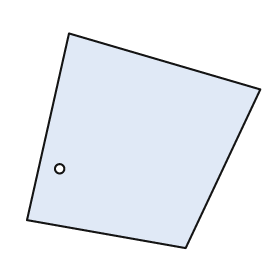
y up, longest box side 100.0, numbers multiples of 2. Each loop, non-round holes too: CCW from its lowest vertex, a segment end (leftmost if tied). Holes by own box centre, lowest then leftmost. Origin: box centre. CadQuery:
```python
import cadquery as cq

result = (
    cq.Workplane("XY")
    .moveTo(18.0, -46.0)
    .lineTo(50.0, 22.0)
    .lineTo(-32.0, 46.0)
    .lineTo(-50.0, -34.0)
    .close()
    .moveTo(-36.0, -12.0)
    .circle(2.0)
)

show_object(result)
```